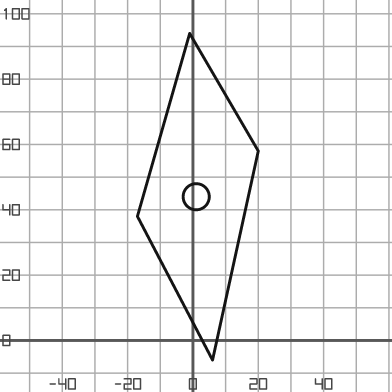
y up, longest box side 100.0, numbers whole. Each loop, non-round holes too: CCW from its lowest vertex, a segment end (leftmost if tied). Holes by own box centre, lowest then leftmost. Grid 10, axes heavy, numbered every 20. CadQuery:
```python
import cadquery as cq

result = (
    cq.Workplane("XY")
    .moveTo(6.0, -6.0)
    .lineTo(20.0, 58.0)
    .lineTo(-1.0, 94.0)
    .lineTo(-17.0, 38.0)
    .close()
    .moveTo(1.0, 44.0)
    .circle(4.0)
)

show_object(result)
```